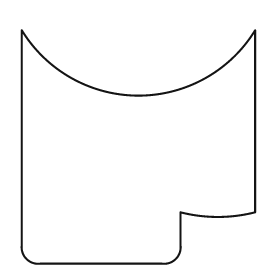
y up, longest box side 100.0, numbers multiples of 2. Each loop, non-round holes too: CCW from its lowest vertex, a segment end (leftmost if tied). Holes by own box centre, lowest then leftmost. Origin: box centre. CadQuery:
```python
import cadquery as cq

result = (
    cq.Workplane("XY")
    .moveTo(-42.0, -50.0)
    .lineTo(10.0, -50.0)
    .threePointArc((16.0, -48.0), (18.0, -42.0))
    .lineTo(18.0, -28.0)
    .threePointArc((34.0, -30.0), (50.0, -28.0))
    .lineTo(50.0, 50.0)
    .threePointArc((0.0, 22.0), (-50.0, 50.0))
    .lineTo(-50.0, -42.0)
    .threePointArc((-48.0, -48.0), (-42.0, -50.0))
    .close()
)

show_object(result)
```